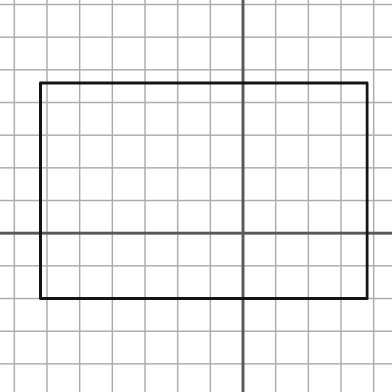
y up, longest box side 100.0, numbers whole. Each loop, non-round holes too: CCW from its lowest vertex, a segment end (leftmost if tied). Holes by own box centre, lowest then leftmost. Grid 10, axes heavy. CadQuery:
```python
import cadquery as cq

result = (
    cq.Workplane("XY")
    .moveTo(-62.0, -20.0)
    .lineTo(38.0, -20.0)
    .lineTo(38.0, 46.0)
    .lineTo(-62.0, 46.0)
    .close()
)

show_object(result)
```